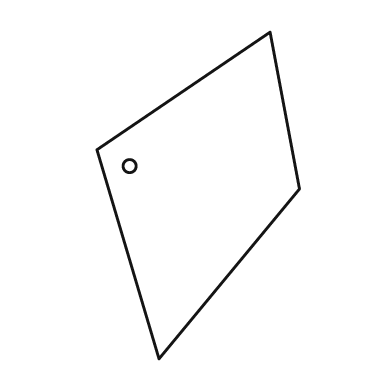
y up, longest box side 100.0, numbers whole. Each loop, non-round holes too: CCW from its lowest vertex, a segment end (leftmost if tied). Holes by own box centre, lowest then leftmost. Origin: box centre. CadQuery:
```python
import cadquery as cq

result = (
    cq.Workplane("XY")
    .moveTo(-12.0, -50.0)
    .lineTo(31.0, 2.0)
    .lineTo(22.0, 50.0)
    .lineTo(-31.0, 14.0)
    .close()
    .moveTo(-21.0, 9.0)
    .circle(2.0)
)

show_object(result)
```